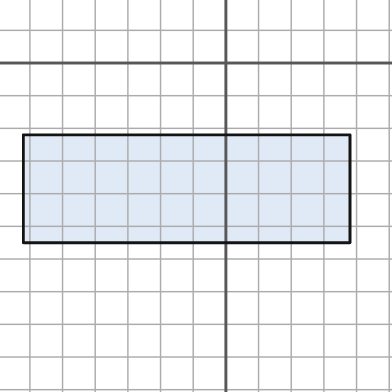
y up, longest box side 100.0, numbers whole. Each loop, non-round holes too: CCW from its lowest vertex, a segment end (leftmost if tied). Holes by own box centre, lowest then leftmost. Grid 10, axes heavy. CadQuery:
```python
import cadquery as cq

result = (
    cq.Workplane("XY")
    .moveTo(-62.0, -55.0)
    .lineTo(38.0, -55.0)
    .lineTo(38.0, -22.0)
    .lineTo(-62.0, -22.0)
    .close()
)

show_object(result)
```